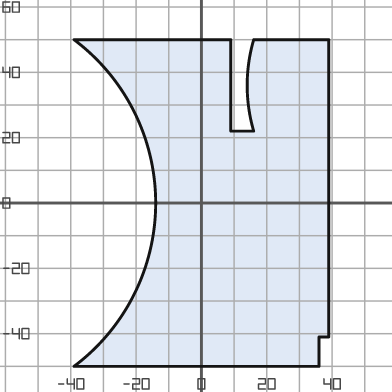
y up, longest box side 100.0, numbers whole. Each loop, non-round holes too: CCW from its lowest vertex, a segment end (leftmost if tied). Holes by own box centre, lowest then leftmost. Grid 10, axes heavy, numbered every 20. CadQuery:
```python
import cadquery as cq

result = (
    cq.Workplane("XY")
    .moveTo(-39.0, -50.0)
    .lineTo(36.0, -50.0)
    .lineTo(36.0, -41.0)
    .lineTo(39.0, -41.0)
    .lineTo(39.0, 50.0)
    .lineTo(16.0, 50.0)
    .threePointArc((14.0, 36.0), (16.0, 22.0))
    .lineTo(9.0, 22.0)
    .lineTo(9.0, 50.0)
    .lineTo(-39.0, 50.0)
    .threePointArc((-14.0, 0.0), (-39.0, -50.0))
    .close()
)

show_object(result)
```